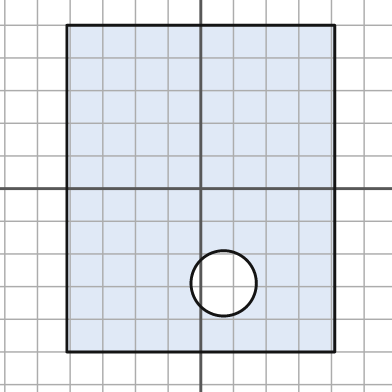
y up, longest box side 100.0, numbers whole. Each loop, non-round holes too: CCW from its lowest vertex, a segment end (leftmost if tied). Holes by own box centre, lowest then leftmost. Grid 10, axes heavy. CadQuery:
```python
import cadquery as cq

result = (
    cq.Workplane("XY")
    .moveTo(-41.0, -50.0)
    .lineTo(41.0, -50.0)
    .lineTo(41.0, 50.0)
    .lineTo(-41.0, 50.0)
    .close()
    .moveTo(7.0, -29.0)
    .circle(10.0)
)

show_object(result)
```